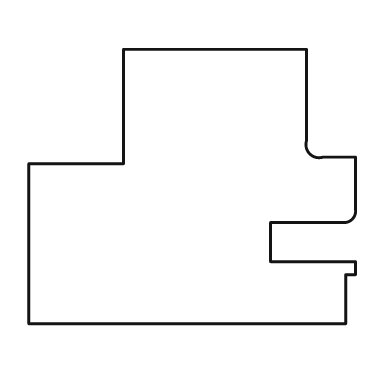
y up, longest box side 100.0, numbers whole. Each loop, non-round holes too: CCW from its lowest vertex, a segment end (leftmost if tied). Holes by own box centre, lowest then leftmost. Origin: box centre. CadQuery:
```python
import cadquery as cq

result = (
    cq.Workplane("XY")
    .moveTo(-50.0, -42.0)
    .lineTo(47.0, -42.0)
    .lineTo(47.0, -27.0)
    .lineTo(50.0, -27.0)
    .lineTo(50.0, -23.0)
    .lineTo(24.0, -23.0)
    .lineTo(24.0, -11.0)
    .lineTo(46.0, -11.0)
    .threePointArc((49.0, -10.0), (50.0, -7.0))
    .lineTo(50.0, 9.0)
    .lineTo(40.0, 9.0)
    .threePointArc((36.0, 10.0), (35.0, 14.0))
    .lineTo(35.0, 42.0)
    .lineTo(-21.0, 42.0)
    .lineTo(-21.0, 7.0)
    .lineTo(-50.0, 7.0)
    .close()
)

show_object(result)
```